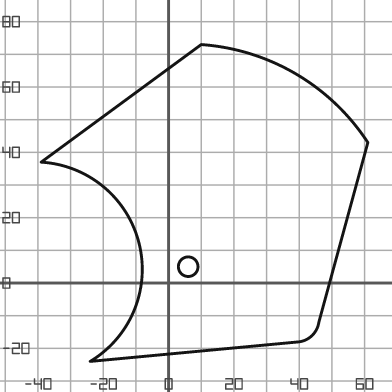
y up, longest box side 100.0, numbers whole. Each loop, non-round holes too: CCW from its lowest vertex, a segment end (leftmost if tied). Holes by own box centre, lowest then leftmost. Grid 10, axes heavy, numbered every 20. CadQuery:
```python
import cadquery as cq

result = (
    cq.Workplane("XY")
    .moveTo(-24.0, -24.0)
    .lineTo(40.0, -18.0)
    .threePointArc((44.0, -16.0), (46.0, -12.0))
    .lineTo(61.0, 43.0)
    .threePointArc((39.0, 64.0), (10.0, 73.0))
    .lineTo(-39.0, 37.0)
    .threePointArc((-9.0, 12.0), (-24.0, -24.0))
    .close()
    .moveTo(6.0, 5.0)
    .circle(3.0)
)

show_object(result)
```